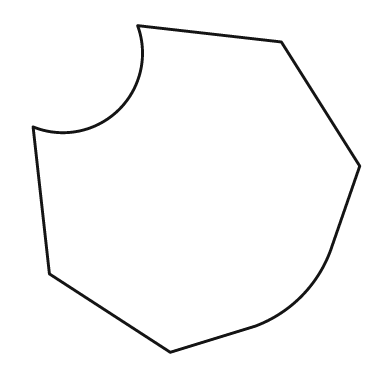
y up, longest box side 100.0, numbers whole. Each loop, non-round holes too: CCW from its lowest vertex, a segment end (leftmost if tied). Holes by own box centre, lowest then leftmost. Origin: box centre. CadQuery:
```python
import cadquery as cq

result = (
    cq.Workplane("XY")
    .moveTo(-8.0, -50.0)
    .lineTo(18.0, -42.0)
    .threePointArc((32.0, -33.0), (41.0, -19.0))
    .lineTo(50.0, 7.0)
    .lineTo(26.0, 45.0)
    .lineTo(-18.0, 50.0)
    .threePointArc((-24.0, 24.0), (-50.0, 19.0))
    .lineTo(-45.0, -26.0)
    .close()
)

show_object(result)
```